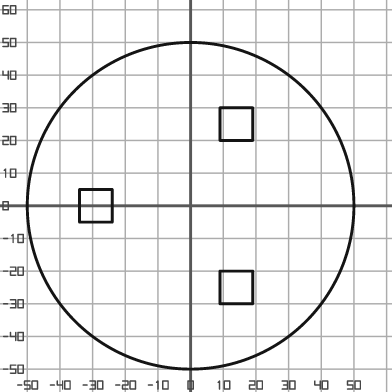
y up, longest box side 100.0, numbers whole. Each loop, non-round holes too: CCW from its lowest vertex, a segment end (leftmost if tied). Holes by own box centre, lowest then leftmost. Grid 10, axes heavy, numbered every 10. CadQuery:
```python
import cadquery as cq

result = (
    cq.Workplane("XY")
    .moveTo(0.0, 0.0)
    .circle(50.0)
    .moveTo(9.0, -30.0)
    .lineTo(19.0, -30.0)
    .lineTo(19.0, -20.0)
    .lineTo(9.0, -20.0)
    .close()
    .moveTo(-34.0, -5.0)
    .lineTo(-24.0, -5.0)
    .lineTo(-24.0, 5.0)
    .lineTo(-34.0, 5.0)
    .close()
    .moveTo(9.0, 20.0)
    .lineTo(19.0, 20.0)
    .lineTo(19.0, 30.0)
    .lineTo(9.0, 30.0)
    .close()
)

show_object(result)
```